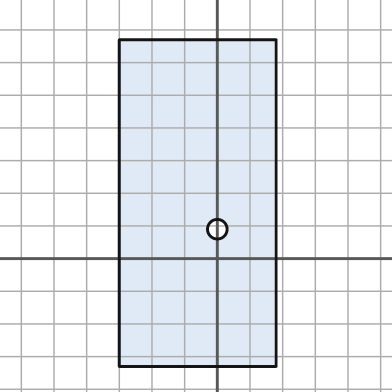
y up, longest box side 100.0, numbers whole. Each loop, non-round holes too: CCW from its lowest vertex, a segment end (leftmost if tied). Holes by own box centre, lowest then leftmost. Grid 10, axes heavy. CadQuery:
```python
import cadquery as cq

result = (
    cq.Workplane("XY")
    .moveTo(-30.0, -33.0)
    .lineTo(18.0, -33.0)
    .lineTo(18.0, 67.0)
    .lineTo(-30.0, 67.0)
    .close()
    .moveTo(0.0, 9.0)
    .circle(3.0)
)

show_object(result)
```